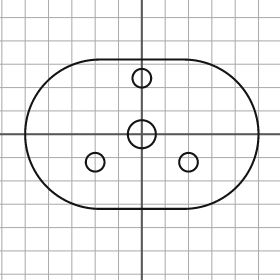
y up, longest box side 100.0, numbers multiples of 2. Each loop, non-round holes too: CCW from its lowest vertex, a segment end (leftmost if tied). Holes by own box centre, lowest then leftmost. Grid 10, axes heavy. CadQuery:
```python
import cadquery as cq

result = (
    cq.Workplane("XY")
    .moveTo(-18.0, -32.0)
    .lineTo(18.0, -32.0)
    .threePointArc((50.0, 0.0), (18.0, 32.0))
    .lineTo(-18.0, 32.0)
    .threePointArc((-50.0, 0.0), (-18.0, -32.0))
    .close()
    .moveTo(-20.0, -12.0)
    .circle(4.0)
    .moveTo(20.0, -12.0)
    .circle(4.0)
    .moveTo(0.0, 0.0)
    .circle(6.0)
    .moveTo(0.0, 24.0)
    .circle(4.0)
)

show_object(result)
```